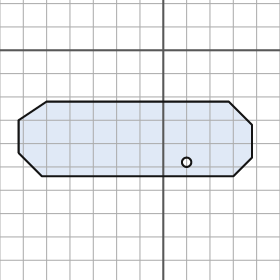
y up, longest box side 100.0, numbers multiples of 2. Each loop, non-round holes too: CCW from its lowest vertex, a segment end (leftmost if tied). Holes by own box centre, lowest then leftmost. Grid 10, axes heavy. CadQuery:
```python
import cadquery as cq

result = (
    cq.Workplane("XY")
    .moveTo(-52.0, -54.0)
    .lineTo(30.0, -54.0)
    .lineTo(38.0, -46.0)
    .lineTo(38.0, -32.0)
    .lineTo(28.0, -22.0)
    .lineTo(-50.0, -22.0)
    .lineTo(-62.0, -30.0)
    .lineTo(-62.0, -44.0)
    .close()
    .moveTo(10.0, -48.0)
    .circle(2.0)
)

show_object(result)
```